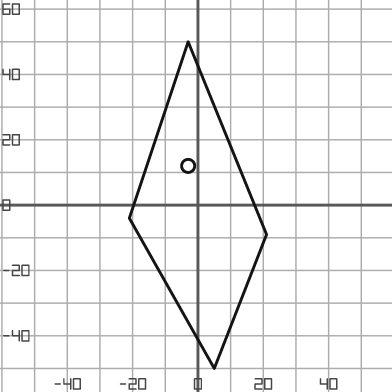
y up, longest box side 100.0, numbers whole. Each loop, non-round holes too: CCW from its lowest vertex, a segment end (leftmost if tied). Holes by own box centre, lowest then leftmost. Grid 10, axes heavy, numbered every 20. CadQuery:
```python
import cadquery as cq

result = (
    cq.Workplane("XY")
    .moveTo(5.0, -50.0)
    .lineTo(21.0, -9.0)
    .lineTo(-3.0, 50.0)
    .lineTo(-21.0, -4.0)
    .close()
    .moveTo(-3.0, 12.0)
    .circle(2.0)
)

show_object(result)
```